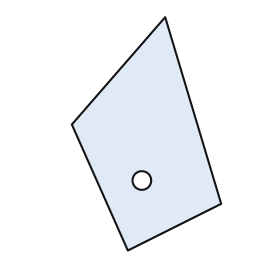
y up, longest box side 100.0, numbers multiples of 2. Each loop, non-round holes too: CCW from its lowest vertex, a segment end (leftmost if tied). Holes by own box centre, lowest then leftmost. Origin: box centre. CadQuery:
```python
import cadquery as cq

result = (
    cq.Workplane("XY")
    .moveTo(-8.0, -50.0)
    .lineTo(32.0, -30.0)
    .lineTo(8.0, 50.0)
    .lineTo(-32.0, 4.0)
    .close()
    .moveTo(-2.0, -20.0)
    .circle(4.0)
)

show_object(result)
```